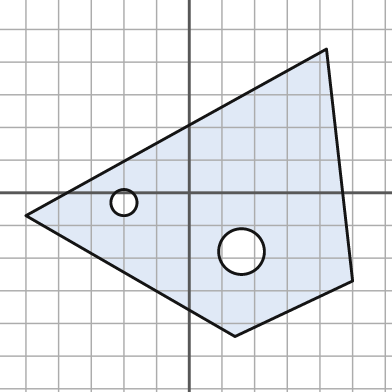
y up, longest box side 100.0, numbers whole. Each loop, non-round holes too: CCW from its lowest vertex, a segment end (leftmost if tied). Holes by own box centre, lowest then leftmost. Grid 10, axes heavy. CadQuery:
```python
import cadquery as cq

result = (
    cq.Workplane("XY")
    .moveTo(14.0, -44.0)
    .lineTo(50.0, -27.0)
    .lineTo(42.0, 44.0)
    .lineTo(-50.0, -7.0)
    .close()
    .moveTo(16.0, -18.0)
    .circle(7.0)
    .moveTo(-20.0, -3.0)
    .circle(4.0)
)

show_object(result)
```